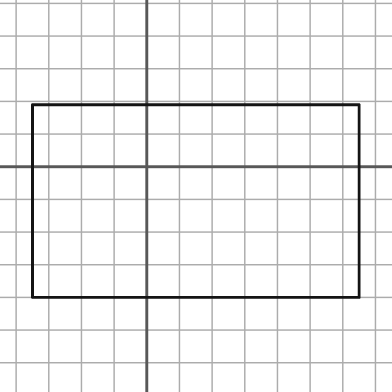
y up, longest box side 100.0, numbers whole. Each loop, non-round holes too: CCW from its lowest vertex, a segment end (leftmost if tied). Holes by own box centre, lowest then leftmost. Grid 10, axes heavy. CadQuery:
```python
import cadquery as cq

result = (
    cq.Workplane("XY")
    .moveTo(-35.0, -40.0)
    .lineTo(65.0, -40.0)
    .lineTo(65.0, 19.0)
    .lineTo(-35.0, 19.0)
    .close()
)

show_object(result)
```